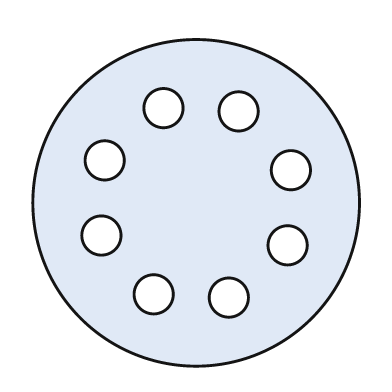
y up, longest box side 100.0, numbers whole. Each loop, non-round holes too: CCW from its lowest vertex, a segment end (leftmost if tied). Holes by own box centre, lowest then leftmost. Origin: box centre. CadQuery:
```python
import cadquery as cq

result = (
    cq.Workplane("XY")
    .moveTo(0.0, 0.0)
    .circle(50.0)
    .moveTo(10.0, -29.0)
    .circle(6.0)
    .moveTo(-13.0, -28.0)
    .circle(6.0)
    .moveTo(28.0, -13.0)
    .circle(6.0)
    .moveTo(-29.0, -10.0)
    .circle(6.0)
    .moveTo(29.0, 10.0)
    .circle(6.0)
    .moveTo(-28.0, 13.0)
    .circle(6.0)
    .moveTo(13.0, 28.0)
    .circle(6.0)
    .moveTo(-10.0, 29.0)
    .circle(6.0)
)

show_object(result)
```